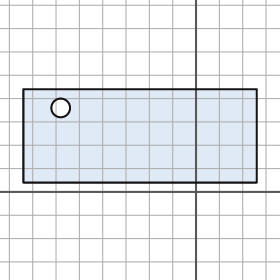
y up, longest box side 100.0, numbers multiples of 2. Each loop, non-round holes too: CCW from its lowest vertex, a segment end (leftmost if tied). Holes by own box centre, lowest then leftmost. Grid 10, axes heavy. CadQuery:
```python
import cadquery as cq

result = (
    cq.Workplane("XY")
    .moveTo(-74.0, 4.0)
    .lineTo(26.0, 4.0)
    .lineTo(26.0, 44.0)
    .lineTo(-74.0, 44.0)
    .close()
    .moveTo(-58.0, 36.0)
    .circle(4.0)
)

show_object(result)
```